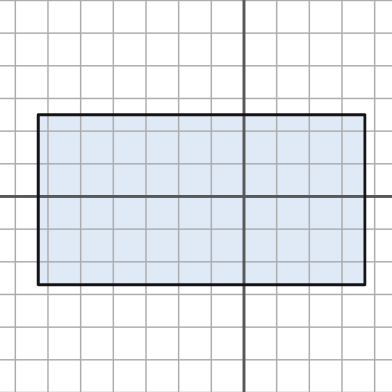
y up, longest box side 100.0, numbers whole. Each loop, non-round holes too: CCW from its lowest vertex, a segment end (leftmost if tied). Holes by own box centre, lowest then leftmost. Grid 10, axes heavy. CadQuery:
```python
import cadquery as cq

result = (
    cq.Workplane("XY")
    .moveTo(-63.0, -27.0)
    .lineTo(37.0, -27.0)
    .lineTo(37.0, 25.0)
    .lineTo(-63.0, 25.0)
    .close()
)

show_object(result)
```